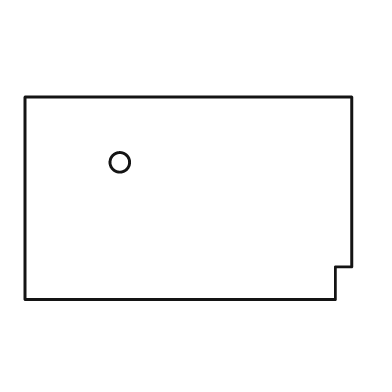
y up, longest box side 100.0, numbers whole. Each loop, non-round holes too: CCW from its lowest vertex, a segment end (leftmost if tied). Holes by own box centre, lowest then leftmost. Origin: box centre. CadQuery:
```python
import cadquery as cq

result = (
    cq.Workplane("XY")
    .moveTo(-50.0, -31.0)
    .lineTo(45.0, -31.0)
    .lineTo(45.0, -21.0)
    .lineTo(50.0, -21.0)
    .lineTo(50.0, 31.0)
    .lineTo(-50.0, 31.0)
    .close()
    .moveTo(-21.0, 11.0)
    .circle(3.0)
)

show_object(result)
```